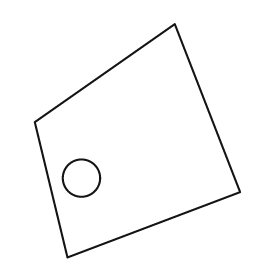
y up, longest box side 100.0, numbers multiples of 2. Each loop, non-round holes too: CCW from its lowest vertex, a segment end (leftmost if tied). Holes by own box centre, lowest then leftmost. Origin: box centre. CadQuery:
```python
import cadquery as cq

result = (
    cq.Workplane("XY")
    .moveTo(-30.0, -50.0)
    .lineTo(44.0, -22.0)
    .lineTo(16.0, 50.0)
    .lineTo(-44.0, 8.0)
    .close()
    .moveTo(-24.0, -16.0)
    .circle(8.0)
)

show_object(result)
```